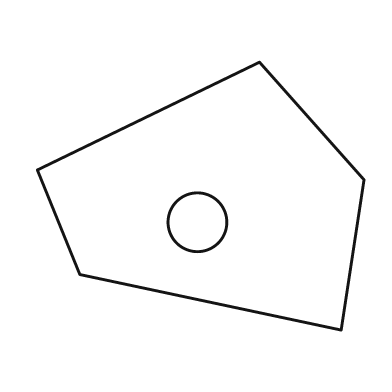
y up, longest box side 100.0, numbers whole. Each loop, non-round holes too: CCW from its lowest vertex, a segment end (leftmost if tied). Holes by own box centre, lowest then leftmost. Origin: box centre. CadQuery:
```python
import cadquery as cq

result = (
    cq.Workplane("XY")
    .moveTo(43.0, -41.0)
    .lineTo(50.0, 5.0)
    .lineTo(18.0, 41.0)
    .lineTo(-50.0, 8.0)
    .lineTo(-37.0, -24.0)
    .close()
    .moveTo(-1.0, -8.0)
    .circle(9.0)
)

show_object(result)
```